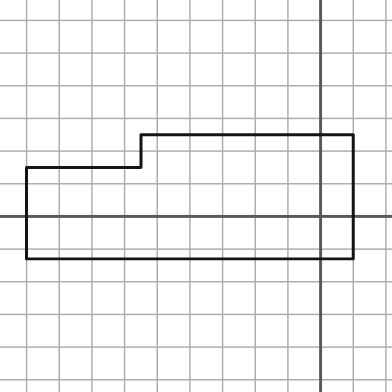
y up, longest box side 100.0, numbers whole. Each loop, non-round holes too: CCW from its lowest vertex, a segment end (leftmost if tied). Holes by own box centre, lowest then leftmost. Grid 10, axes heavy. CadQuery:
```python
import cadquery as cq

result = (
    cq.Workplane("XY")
    .moveTo(-90.0, -13.0)
    .lineTo(10.0, -13.0)
    .lineTo(10.0, 25.0)
    .lineTo(-55.0, 25.0)
    .lineTo(-55.0, 15.0)
    .lineTo(-90.0, 15.0)
    .close()
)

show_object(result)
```